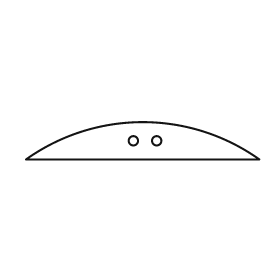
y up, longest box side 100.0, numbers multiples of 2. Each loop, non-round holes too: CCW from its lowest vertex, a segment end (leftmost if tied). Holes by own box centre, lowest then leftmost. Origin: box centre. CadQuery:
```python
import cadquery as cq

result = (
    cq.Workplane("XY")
    .moveTo(-50.0, -8.0)
    .lineTo(50.0, -8.0)
    .threePointArc((0.0, 8.0), (-50.0, -8.0))
    .close()
    .moveTo(-4.0, 0.0)
    .circle(2.0)
    .moveTo(6.0, 0.0)
    .circle(2.0)
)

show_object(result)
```